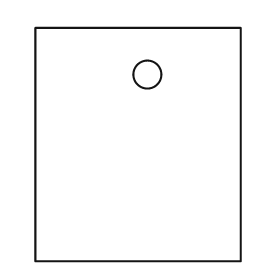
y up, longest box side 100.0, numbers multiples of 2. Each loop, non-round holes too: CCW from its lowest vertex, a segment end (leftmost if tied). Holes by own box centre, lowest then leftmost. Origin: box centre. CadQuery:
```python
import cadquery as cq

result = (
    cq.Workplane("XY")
    .moveTo(-44.0, -50.0)
    .lineTo(44.0, -50.0)
    .lineTo(44.0, 50.0)
    .lineTo(-44.0, 50.0)
    .close()
    .moveTo(4.0, 30.0)
    .circle(6.0)
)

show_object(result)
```